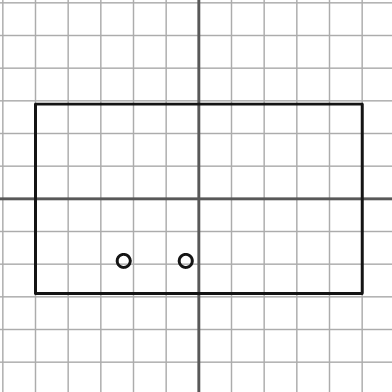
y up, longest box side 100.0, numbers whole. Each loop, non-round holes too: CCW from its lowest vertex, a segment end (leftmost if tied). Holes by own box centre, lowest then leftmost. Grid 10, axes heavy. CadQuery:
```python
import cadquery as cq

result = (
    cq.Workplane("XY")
    .moveTo(-50.0, -29.0)
    .lineTo(50.0, -29.0)
    .lineTo(50.0, 29.0)
    .lineTo(-50.0, 29.0)
    .close()
    .moveTo(-23.0, -19.0)
    .circle(2.0)
    .moveTo(-4.0, -19.0)
    .circle(2.0)
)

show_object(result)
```